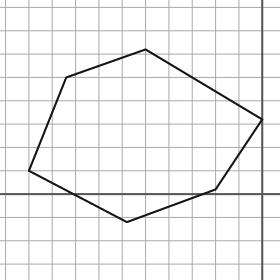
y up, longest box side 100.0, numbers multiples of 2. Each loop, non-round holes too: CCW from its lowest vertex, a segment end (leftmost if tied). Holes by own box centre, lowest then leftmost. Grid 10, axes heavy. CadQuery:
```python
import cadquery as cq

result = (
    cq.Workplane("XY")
    .moveTo(-58.0, -12.0)
    .lineTo(-20.0, 2.0)
    .lineTo(0.0, 32.0)
    .lineTo(-50.0, 62.0)
    .lineTo(-84.0, 50.0)
    .lineTo(-100.0, 10.0)
    .close()
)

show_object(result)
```